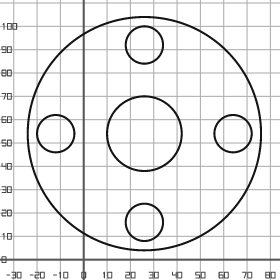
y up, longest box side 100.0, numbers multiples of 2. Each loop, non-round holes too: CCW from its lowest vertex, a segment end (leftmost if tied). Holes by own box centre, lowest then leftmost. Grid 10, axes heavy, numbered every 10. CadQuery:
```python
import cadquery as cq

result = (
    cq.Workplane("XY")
    .moveTo(26.0, 54.0)
    .circle(50.0)
    .moveTo(26.0, 16.0)
    .circle(8.0)
    .moveTo(-12.0, 54.0)
    .circle(8.0)
    .moveTo(26.0, 54.0)
    .circle(16.0)
    .moveTo(64.0, 54.0)
    .circle(8.0)
    .moveTo(26.0, 92.0)
    .circle(8.0)
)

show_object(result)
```